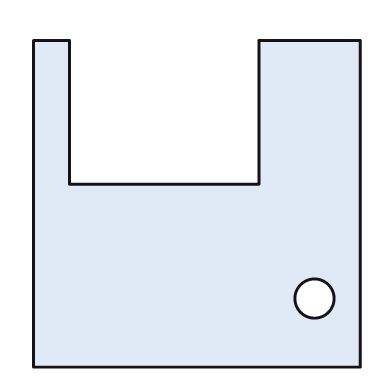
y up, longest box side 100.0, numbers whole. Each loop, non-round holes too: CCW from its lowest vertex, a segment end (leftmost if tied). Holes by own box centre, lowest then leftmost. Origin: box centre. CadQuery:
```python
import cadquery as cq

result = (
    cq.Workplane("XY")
    .moveTo(-50.0, -50.0)
    .lineTo(50.0, -50.0)
    .lineTo(50.0, 50.0)
    .lineTo(19.0, 50.0)
    .lineTo(19.0, 6.0)
    .lineTo(-39.0, 6.0)
    .lineTo(-39.0, 50.0)
    .lineTo(-50.0, 50.0)
    .close()
    .moveTo(36.0, -29.0)
    .circle(6.0)
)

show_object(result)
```